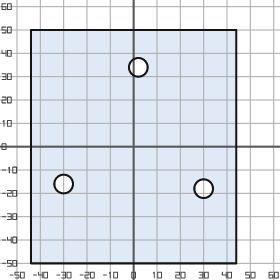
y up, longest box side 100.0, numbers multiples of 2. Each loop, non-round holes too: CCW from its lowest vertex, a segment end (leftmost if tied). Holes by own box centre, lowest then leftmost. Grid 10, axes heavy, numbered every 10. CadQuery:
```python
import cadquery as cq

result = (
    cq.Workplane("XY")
    .moveTo(-44.0, -50.0)
    .lineTo(44.0, -50.0)
    .lineTo(44.0, 50.0)
    .lineTo(-44.0, 50.0)
    .close()
    .moveTo(30.0, -18.0)
    .circle(4.0)
    .moveTo(-30.0, -16.0)
    .circle(4.0)
    .moveTo(2.0, 34.0)
    .circle(4.0)
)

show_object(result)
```